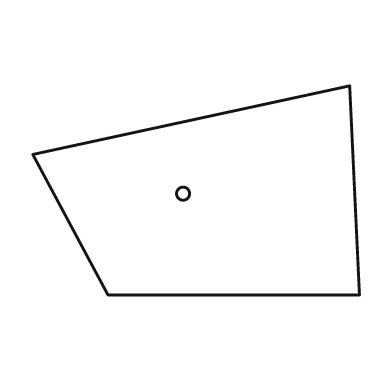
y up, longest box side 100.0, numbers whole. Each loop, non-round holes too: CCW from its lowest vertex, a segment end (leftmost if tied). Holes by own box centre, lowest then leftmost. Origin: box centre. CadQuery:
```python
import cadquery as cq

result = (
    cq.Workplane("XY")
    .moveTo(-27.0, -32.0)
    .lineTo(50.0, -32.0)
    .lineTo(47.0, 32.0)
    .lineTo(-50.0, 11.0)
    .close()
    .moveTo(-4.0, -1.0)
    .circle(2.0)
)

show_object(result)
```